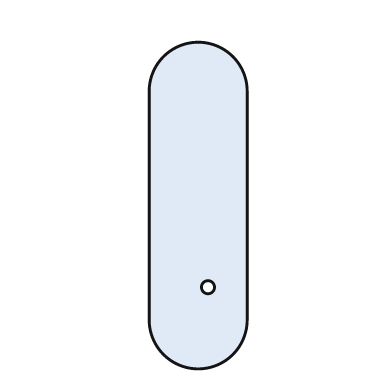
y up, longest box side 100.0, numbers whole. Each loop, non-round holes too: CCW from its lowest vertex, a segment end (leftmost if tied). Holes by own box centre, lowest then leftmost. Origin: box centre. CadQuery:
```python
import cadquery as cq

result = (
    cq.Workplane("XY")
    .moveTo(-15.0, -35.0)
    .threePointArc((0.0, -50.0), (15.0, -35.0))
    .lineTo(15.0, 35.0)
    .threePointArc((0.0, 50.0), (-15.0, 35.0))
    .close()
    .moveTo(3.0, -25.0)
    .circle(2.0)
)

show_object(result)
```